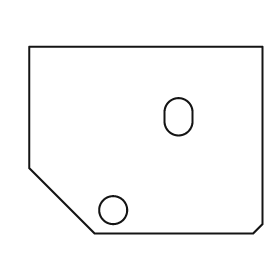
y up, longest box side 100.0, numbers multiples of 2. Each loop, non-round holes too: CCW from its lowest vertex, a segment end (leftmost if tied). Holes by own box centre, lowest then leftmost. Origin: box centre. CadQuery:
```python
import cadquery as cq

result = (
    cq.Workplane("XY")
    .moveTo(-22.0, -40.0)
    .lineTo(46.0, -40.0)
    .lineTo(50.0, -36.0)
    .lineTo(50.0, 40.0)
    .lineTo(-50.0, 40.0)
    .lineTo(-50.0, -12.0)
    .close()
    .moveTo(-14.0, -30.0)
    .circle(6.0)
    .moveTo(8.0, 8.0)
    .threePointArc((14.0, 2.0), (20.0, 8.0))
    .lineTo(20.0, 12.0)
    .threePointArc((14.0, 18.0), (8.0, 12.0))
    .close()
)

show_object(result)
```